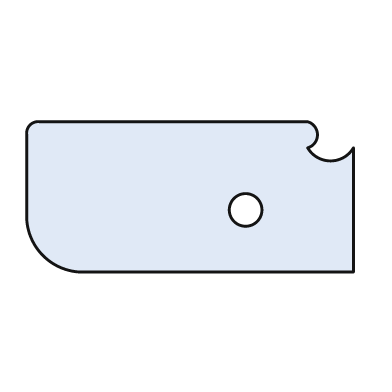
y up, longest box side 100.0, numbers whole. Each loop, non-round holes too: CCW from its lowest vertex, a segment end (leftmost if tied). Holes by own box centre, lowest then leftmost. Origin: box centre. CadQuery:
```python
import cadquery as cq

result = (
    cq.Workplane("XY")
    .moveTo(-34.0, -23.0)
    .lineTo(50.0, -23.0)
    .lineTo(50.0, 15.0)
    .threePointArc((43.0, 11.0), (36.0, 15.0))
    .threePointArc((39.0, 19.0), (36.0, 23.0))
    .lineTo(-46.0, 23.0)
    .threePointArc((-49.0, 22.0), (-50.0, 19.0))
    .lineTo(-50.0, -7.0)
    .threePointArc((-45.0, -18.0), (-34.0, -23.0))
    .close()
    .moveTo(17.0, -4.0)
    .circle(5.0)
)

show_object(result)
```